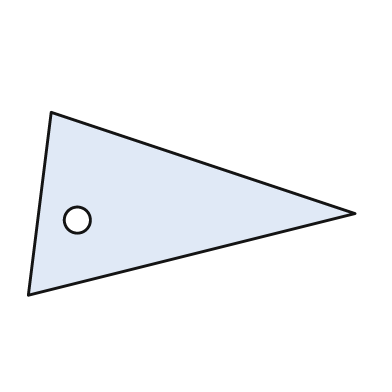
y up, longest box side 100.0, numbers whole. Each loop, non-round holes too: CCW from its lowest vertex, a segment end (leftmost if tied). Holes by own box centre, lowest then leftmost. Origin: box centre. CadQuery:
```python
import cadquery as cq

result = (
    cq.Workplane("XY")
    .moveTo(-50.0, -28.0)
    .lineTo(50.0, -3.0)
    .lineTo(-43.0, 28.0)
    .close()
    .moveTo(-35.0, -5.0)
    .circle(4.0)
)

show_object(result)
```